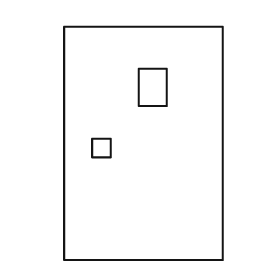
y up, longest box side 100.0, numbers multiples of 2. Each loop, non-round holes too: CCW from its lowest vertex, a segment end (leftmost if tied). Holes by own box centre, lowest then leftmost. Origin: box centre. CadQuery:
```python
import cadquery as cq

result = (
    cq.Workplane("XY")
    .moveTo(-34.0, -50.0)
    .lineTo(34.0, -50.0)
    .lineTo(34.0, 50.0)
    .lineTo(-34.0, 50.0)
    .close()
    .moveTo(-22.0, -6.0)
    .lineTo(-14.0, -6.0)
    .lineTo(-14.0, 2.0)
    .lineTo(-22.0, 2.0)
    .close()
    .moveTo(-2.0, 16.0)
    .lineTo(10.0, 16.0)
    .lineTo(10.0, 32.0)
    .lineTo(-2.0, 32.0)
    .close()
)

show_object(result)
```